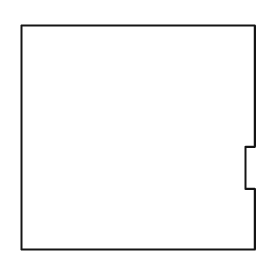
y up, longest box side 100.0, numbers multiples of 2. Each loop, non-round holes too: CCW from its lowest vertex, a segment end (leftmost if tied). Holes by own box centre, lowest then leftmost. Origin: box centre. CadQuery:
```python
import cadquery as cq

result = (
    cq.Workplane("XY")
    .moveTo(-50.0, -48.0)
    .lineTo(50.0, -48.0)
    .lineTo(50.0, -22.0)
    .lineTo(46.0, -22.0)
    .lineTo(46.0, -4.0)
    .lineTo(50.0, -4.0)
    .lineTo(50.0, 48.0)
    .lineTo(-50.0, 48.0)
    .close()
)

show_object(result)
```